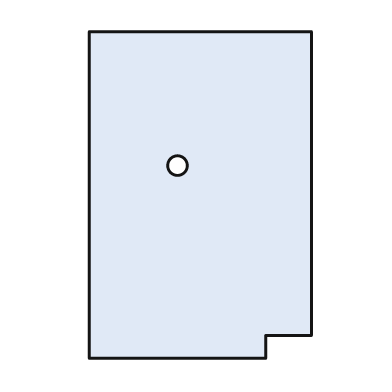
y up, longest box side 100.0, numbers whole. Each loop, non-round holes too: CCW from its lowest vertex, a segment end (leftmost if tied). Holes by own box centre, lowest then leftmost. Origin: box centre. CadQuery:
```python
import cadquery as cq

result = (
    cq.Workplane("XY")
    .moveTo(-34.0, -50.0)
    .lineTo(20.0, -50.0)
    .lineTo(20.0, -43.0)
    .lineTo(34.0, -43.0)
    .lineTo(34.0, 50.0)
    .lineTo(-34.0, 50.0)
    .close()
    .moveTo(-7.0, 9.0)
    .circle(3.0)
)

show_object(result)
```